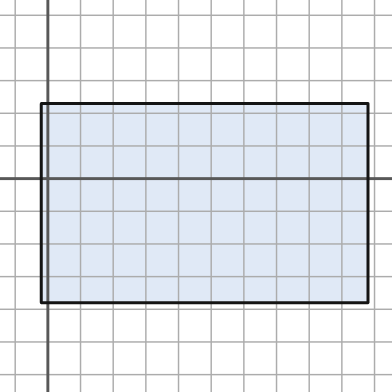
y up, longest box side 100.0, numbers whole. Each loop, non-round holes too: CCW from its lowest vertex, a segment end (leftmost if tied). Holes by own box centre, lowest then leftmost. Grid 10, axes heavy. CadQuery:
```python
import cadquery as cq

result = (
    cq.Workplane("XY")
    .moveTo(-2.0, -38.0)
    .lineTo(98.0, -38.0)
    .lineTo(98.0, 23.0)
    .lineTo(-2.0, 23.0)
    .close()
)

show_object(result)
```